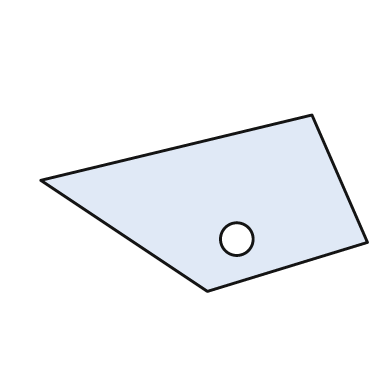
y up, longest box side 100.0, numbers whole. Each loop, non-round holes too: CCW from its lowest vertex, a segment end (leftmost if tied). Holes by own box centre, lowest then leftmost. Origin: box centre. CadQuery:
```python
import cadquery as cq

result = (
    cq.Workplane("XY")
    .moveTo(1.0, -27.0)
    .lineTo(50.0, -12.0)
    .lineTo(33.0, 27.0)
    .lineTo(-50.0, 7.0)
    .close()
    .moveTo(10.0, -11.0)
    .circle(5.0)
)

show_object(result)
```